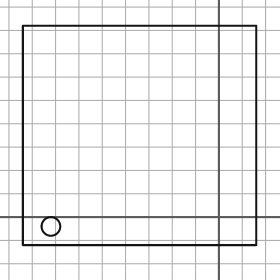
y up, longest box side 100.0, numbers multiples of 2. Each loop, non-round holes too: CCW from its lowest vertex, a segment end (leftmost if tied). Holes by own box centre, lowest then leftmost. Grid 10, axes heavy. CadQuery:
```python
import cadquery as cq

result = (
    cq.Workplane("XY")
    .moveTo(-84.0, -12.0)
    .lineTo(16.0, -12.0)
    .lineTo(16.0, 82.0)
    .lineTo(-84.0, 82.0)
    .close()
    .moveTo(-72.0, -4.0)
    .circle(4.0)
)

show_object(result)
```